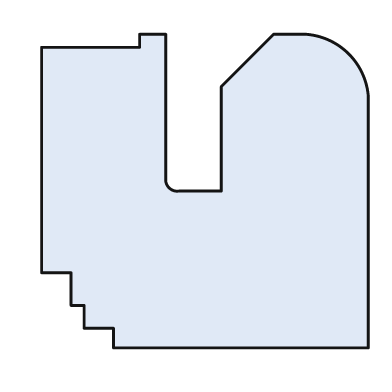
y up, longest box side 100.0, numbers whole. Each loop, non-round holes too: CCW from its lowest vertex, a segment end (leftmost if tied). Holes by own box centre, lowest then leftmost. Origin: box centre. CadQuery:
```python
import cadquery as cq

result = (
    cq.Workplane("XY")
    .moveTo(-28.0, -48.0)
    .lineTo(50.0, -48.0)
    .lineTo(50.0, 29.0)
    .threePointArc((44.0, 42.0), (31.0, 48.0))
    .lineTo(21.0, 48.0)
    .lineTo(5.0, 32.0)
    .lineTo(5.0, 0.0)
    .lineTo(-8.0, 0.0)
    .threePointArc((-11.0, 1.0), (-12.0, 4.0))
    .lineTo(-12.0, 48.0)
    .lineTo(-20.0, 48.0)
    .lineTo(-20.0, 44.0)
    .lineTo(-50.0, 44.0)
    .lineTo(-50.0, -25.0)
    .lineTo(-41.0, -25.0)
    .lineTo(-41.0, -35.0)
    .lineTo(-37.0, -35.0)
    .lineTo(-37.0, -42.0)
    .lineTo(-28.0, -42.0)
    .close()
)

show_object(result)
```